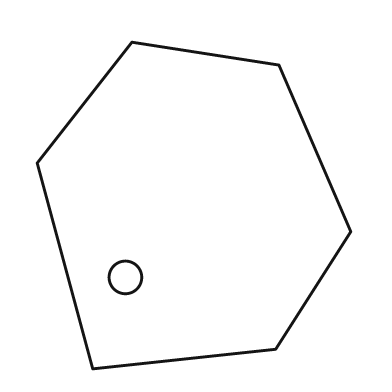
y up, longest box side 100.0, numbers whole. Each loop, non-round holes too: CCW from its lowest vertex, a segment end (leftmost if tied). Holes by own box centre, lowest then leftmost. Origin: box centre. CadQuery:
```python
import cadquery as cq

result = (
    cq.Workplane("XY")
    .moveTo(-31.0, -50.0)
    .lineTo(25.0, -44.0)
    .lineTo(48.0, -8.0)
    .lineTo(26.0, 43.0)
    .lineTo(-19.0, 50.0)
    .lineTo(-48.0, 13.0)
    .close()
    .moveTo(-21.0, -22.0)
    .circle(5.0)
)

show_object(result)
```